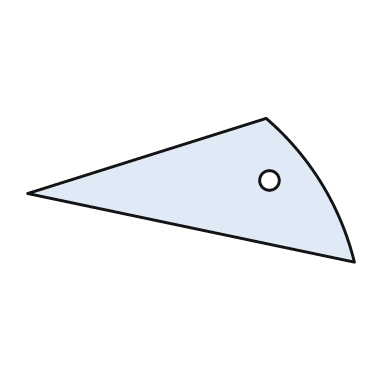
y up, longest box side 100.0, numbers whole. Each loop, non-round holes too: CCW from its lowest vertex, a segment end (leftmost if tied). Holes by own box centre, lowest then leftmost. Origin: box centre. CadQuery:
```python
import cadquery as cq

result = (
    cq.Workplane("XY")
    .moveTo(50.0, -22.0)
    .threePointArc((40.0, 2.0), (23.0, 22.0))
    .lineTo(-50.0, -1.0)
    .close()
    .moveTo(24.0, 3.0)
    .circle(3.0)
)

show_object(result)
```